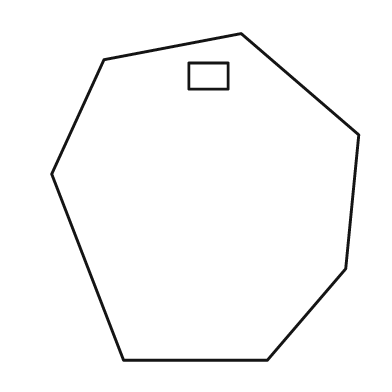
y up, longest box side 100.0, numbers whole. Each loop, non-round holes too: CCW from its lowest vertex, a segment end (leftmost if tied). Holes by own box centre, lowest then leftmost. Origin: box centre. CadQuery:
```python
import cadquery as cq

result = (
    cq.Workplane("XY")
    .moveTo(-25.0, -50.0)
    .lineTo(19.0, -50.0)
    .lineTo(43.0, -22.0)
    .lineTo(47.0, 19.0)
    .lineTo(11.0, 50.0)
    .lineTo(-31.0, 42.0)
    .lineTo(-47.0, 7.0)
    .close()
    .moveTo(-5.0, 33.0)
    .lineTo(7.0, 33.0)
    .lineTo(7.0, 41.0)
    .lineTo(-5.0, 41.0)
    .close()
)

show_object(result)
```